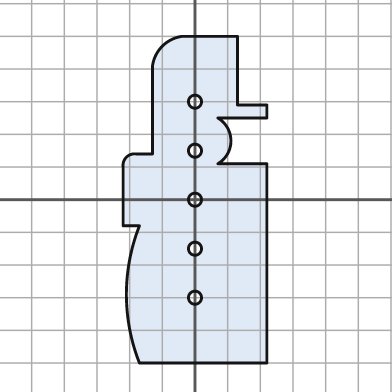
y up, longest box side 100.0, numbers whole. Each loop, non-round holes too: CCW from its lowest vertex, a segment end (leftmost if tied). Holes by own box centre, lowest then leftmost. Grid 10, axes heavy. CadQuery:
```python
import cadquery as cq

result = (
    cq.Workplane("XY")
    .moveTo(-17.0, -50.0)
    .lineTo(22.0, -50.0)
    .lineTo(22.0, 11.0)
    .lineTo(7.0, 11.0)
    .threePointArc((11.0, 18.0), (7.0, 25.0))
    .lineTo(22.0, 25.0)
    .lineTo(22.0, 29.0)
    .lineTo(13.0, 29.0)
    .lineTo(13.0, 50.0)
    .lineTo(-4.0, 50.0)
    .threePointArc((-10.0, 47.0), (-13.0, 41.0))
    .lineTo(-13.0, 14.0)
    .lineTo(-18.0, 14.0)
    .threePointArc((-21.0, 13.0), (-22.0, 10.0))
    .lineTo(-22.0, -8.0)
    .lineTo(-17.0, -8.0)
    .threePointArc((-21.0, -29.0), (-17.0, -50.0))
    .close()
    .moveTo(0.0, -30.0)
    .circle(2.0)
    .moveTo(0.0, -15.0)
    .circle(2.0)
    .moveTo(0.0, 0.0)
    .circle(2.0)
    .moveTo(0.0, 15.0)
    .circle(2.0)
    .moveTo(0.0, 30.0)
    .circle(2.0)
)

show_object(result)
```